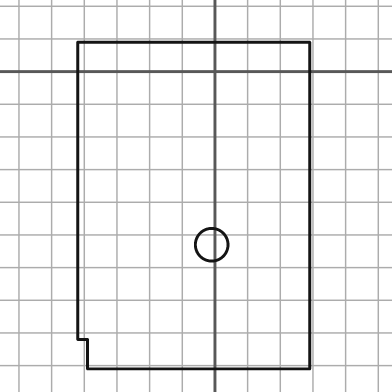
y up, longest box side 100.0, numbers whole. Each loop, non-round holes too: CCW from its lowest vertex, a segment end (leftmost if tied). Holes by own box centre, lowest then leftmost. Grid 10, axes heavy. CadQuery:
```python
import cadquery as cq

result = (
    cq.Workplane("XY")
    .moveTo(-39.0, -91.0)
    .lineTo(29.0, -91.0)
    .lineTo(29.0, 9.0)
    .lineTo(-42.0, 9.0)
    .lineTo(-42.0, -82.0)
    .lineTo(-39.0, -82.0)
    .close()
    .moveTo(-1.0, -53.0)
    .circle(5.0)
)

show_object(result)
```